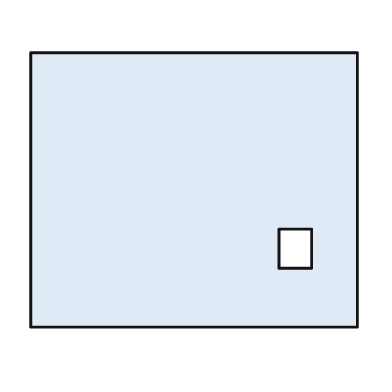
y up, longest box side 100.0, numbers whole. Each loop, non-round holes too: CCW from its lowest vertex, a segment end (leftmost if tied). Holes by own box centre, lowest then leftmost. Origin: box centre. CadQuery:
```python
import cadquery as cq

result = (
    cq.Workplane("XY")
    .moveTo(-50.0, -42.0)
    .lineTo(50.0, -42.0)
    .lineTo(50.0, 42.0)
    .lineTo(-50.0, 42.0)
    .close()
    .moveTo(26.0, -24.0)
    .lineTo(36.0, -24.0)
    .lineTo(36.0, -12.0)
    .lineTo(26.0, -12.0)
    .close()
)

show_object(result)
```